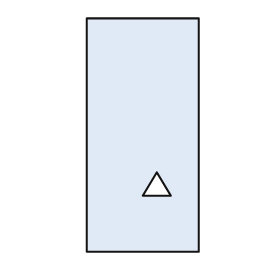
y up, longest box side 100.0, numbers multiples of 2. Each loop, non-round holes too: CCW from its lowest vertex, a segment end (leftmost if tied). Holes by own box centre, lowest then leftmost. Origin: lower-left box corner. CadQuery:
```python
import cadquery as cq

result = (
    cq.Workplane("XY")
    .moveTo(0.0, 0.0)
    .lineTo(48.0, 0.0)
    .lineTo(48.0, 100.0)
    .lineTo(0.0, 100.0)
    .close()
    .moveTo(24.0, 24.0)
    .lineTo(36.0, 24.0)
    .lineTo(30.0, 34.0)
    .close()
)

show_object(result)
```